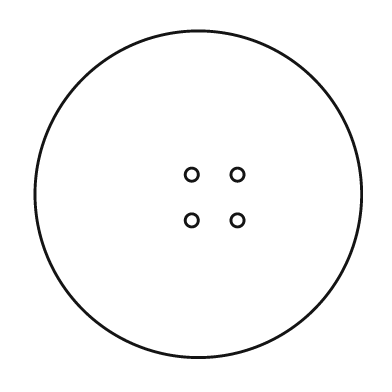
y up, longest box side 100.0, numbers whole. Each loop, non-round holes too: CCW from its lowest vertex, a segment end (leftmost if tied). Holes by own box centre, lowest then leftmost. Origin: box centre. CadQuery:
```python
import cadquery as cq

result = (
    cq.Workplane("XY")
    .moveTo(0.0, 0.0)
    .circle(50.0)
    .moveTo(-2.0, -8.0)
    .circle(2.0)
    .moveTo(12.0, -8.0)
    .circle(2.0)
    .moveTo(-2.0, 6.0)
    .circle(2.0)
    .moveTo(12.0, 6.0)
    .circle(2.0)
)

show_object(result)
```